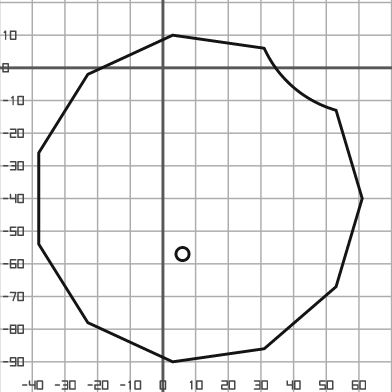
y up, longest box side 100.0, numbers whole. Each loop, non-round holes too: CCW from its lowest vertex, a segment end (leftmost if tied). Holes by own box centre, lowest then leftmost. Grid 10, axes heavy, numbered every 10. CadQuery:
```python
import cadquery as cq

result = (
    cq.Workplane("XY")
    .moveTo(3.0, -90.0)
    .lineTo(31.0, -86.0)
    .lineTo(53.0, -67.0)
    .lineTo(61.0, -40.0)
    .lineTo(53.0, -13.0)
    .threePointArc((40.0, -6.0), (31.0, 6.0))
    .lineTo(3.0, 10.0)
    .lineTo(-23.0, -2.0)
    .lineTo(-38.0, -26.0)
    .lineTo(-38.0, -54.0)
    .lineTo(-23.0, -78.0)
    .close()
    .moveTo(6.0, -57.0)
    .circle(2.0)
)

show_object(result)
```